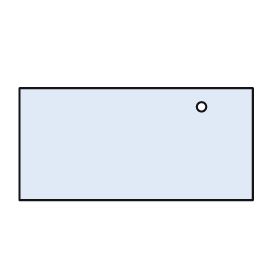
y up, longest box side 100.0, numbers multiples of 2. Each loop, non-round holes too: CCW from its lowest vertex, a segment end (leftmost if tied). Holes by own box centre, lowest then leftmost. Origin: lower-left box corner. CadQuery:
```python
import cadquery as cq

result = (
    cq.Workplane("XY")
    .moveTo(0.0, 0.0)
    .lineTo(100.0, 0.0)
    .lineTo(100.0, 48.0)
    .lineTo(0.0, 48.0)
    .close()
    .moveTo(78.0, 40.0)
    .circle(2.0)
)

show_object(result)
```